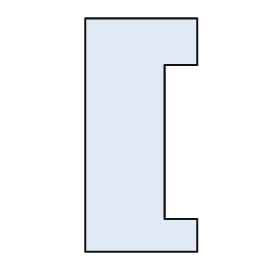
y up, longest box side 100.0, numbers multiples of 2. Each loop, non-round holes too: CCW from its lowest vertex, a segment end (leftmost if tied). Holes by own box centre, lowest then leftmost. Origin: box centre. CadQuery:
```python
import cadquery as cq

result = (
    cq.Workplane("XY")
    .moveTo(-24.0, -50.0)
    .lineTo(24.0, -50.0)
    .lineTo(24.0, -36.0)
    .lineTo(10.0, -36.0)
    .lineTo(10.0, 30.0)
    .lineTo(24.0, 30.0)
    .lineTo(24.0, 50.0)
    .lineTo(-24.0, 50.0)
    .close()
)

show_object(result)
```